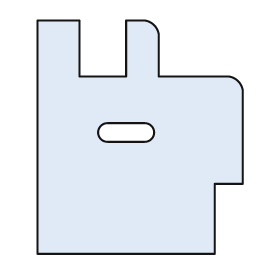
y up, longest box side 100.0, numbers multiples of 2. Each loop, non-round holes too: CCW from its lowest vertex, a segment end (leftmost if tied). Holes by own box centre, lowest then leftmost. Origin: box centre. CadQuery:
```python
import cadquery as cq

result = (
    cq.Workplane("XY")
    .moveTo(-44.0, -50.0)
    .lineTo(32.0, -50.0)
    .lineTo(32.0, -20.0)
    .lineTo(44.0, -20.0)
    .lineTo(44.0, 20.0)
    .threePointArc((42.0, 24.0), (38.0, 26.0))
    .lineTo(8.0, 26.0)
    .lineTo(8.0, 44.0)
    .threePointArc((6.0, 48.0), (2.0, 50.0))
    .lineTo(-6.0, 50.0)
    .lineTo(-6.0, 26.0)
    .lineTo(-26.0, 26.0)
    .lineTo(-26.0, 50.0)
    .lineTo(-44.0, 50.0)
    .close()
    .moveTo(-14.0, -2.0)
    .lineTo(2.0, -2.0)
    .threePointArc((6.0, 2.0), (2.0, 6.0))
    .lineTo(-14.0, 6.0)
    .threePointArc((-18.0, 2.0), (-14.0, -2.0))
    .close()
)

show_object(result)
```